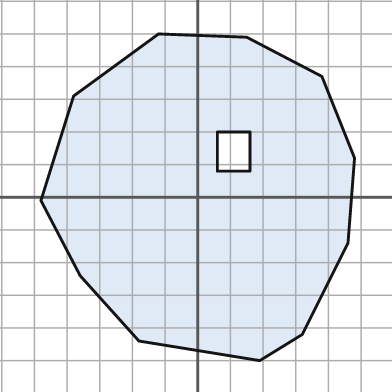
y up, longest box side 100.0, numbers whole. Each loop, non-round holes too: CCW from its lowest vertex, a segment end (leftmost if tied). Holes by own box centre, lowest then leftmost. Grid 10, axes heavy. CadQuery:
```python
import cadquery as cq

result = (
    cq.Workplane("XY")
    .moveTo(19.0, -50.0)
    .lineTo(32.0, -42.0)
    .lineTo(46.0, -14.0)
    .lineTo(48.0, 12.0)
    .lineTo(38.0, 37.0)
    .lineTo(15.0, 49.0)
    .lineTo(-12.0, 50.0)
    .lineTo(-38.0, 31.0)
    .lineTo(-48.0, -1.0)
    .lineTo(-36.0, -24.0)
    .lineTo(-18.0, -44.0)
    .close()
    .moveTo(6.0, 8.0)
    .lineTo(16.0, 8.0)
    .lineTo(16.0, 20.0)
    .lineTo(6.0, 20.0)
    .close()
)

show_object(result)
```